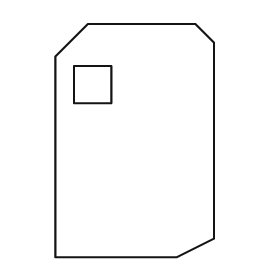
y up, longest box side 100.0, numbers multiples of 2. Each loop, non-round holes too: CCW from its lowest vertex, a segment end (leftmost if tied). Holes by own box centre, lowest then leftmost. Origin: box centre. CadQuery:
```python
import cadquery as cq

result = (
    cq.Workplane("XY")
    .moveTo(-34.0, -50.0)
    .lineTo(18.0, -50.0)
    .lineTo(34.0, -42.0)
    .lineTo(34.0, 42.0)
    .lineTo(26.0, 50.0)
    .lineTo(-20.0, 50.0)
    .lineTo(-34.0, 36.0)
    .close()
    .moveTo(-26.0, 16.0)
    .lineTo(-10.0, 16.0)
    .lineTo(-10.0, 32.0)
    .lineTo(-26.0, 32.0)
    .close()
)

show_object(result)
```